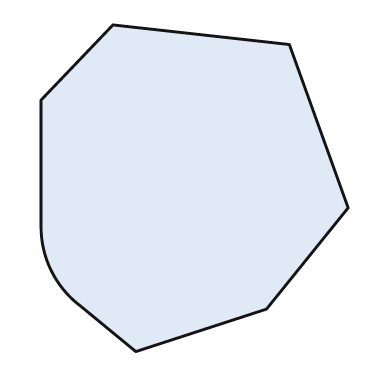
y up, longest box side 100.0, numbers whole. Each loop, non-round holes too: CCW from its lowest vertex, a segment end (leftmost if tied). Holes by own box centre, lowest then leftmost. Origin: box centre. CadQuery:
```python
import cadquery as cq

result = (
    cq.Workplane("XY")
    .moveTo(-18.0, -50.0)
    .lineTo(22.0, -37.0)
    .lineTo(47.0, -6.0)
    .lineTo(29.0, 44.0)
    .lineTo(-25.0, 50.0)
    .lineTo(-47.0, 27.0)
    .lineTo(-47.0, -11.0)
    .threePointArc((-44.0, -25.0), (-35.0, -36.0))
    .close()
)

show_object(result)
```